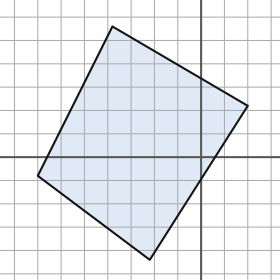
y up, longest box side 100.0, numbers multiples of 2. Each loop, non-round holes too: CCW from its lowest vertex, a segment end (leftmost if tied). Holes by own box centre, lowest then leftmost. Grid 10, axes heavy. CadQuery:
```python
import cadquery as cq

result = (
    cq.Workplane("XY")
    .moveTo(-22.0, -44.0)
    .lineTo(20.0, 22.0)
    .lineTo(-38.0, 56.0)
    .lineTo(-70.0, -8.0)
    .close()
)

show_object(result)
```